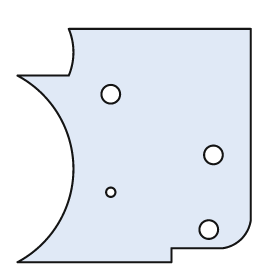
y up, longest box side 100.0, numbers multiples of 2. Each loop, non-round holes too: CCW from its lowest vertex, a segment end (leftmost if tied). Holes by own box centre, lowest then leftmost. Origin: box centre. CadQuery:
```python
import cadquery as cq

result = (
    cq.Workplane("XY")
    .moveTo(-50.0, -50.0)
    .lineTo(16.0, -50.0)
    .lineTo(16.0, -44.0)
    .lineTo(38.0, -44.0)
    .threePointArc((46.0, -40.0), (50.0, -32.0))
    .lineTo(50.0, 50.0)
    .lineTo(-28.0, 50.0)
    .threePointArc((-26.0, 40.0), (-28.0, 30.0))
    .lineTo(-50.0, 30.0)
    .threePointArc((-26.0, -10.0), (-50.0, -50.0))
    .close()
    .moveTo(32.0, -36.0)
    .circle(4.0)
    .moveTo(-10.0, -20.0)
    .circle(2.0)
    .moveTo(34.0, -4.0)
    .circle(4.0)
    .moveTo(-10.0, 22.0)
    .circle(4.0)
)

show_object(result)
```